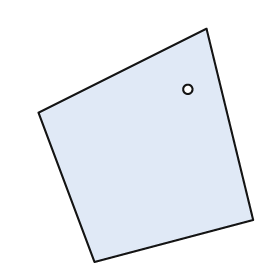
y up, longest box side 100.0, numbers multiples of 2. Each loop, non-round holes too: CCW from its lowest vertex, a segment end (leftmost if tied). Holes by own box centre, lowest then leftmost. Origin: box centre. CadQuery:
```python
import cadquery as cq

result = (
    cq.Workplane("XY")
    .moveTo(-22.0, -50.0)
    .lineTo(46.0, -32.0)
    .lineTo(26.0, 50.0)
    .lineTo(-46.0, 14.0)
    .close()
    .moveTo(18.0, 24.0)
    .circle(2.0)
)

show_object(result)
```